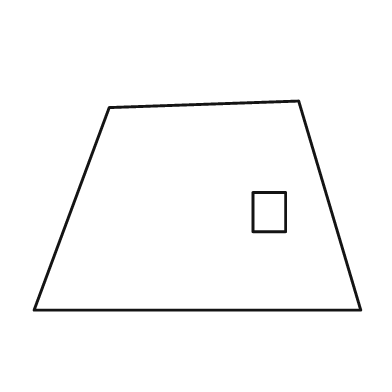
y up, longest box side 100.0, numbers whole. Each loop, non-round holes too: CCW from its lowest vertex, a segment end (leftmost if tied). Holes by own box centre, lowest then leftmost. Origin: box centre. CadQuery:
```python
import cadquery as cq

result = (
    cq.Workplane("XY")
    .moveTo(-50.0, -32.0)
    .lineTo(50.0, -32.0)
    .lineTo(31.0, 32.0)
    .lineTo(-27.0, 30.0)
    .close()
    .moveTo(17.0, -8.0)
    .lineTo(27.0, -8.0)
    .lineTo(27.0, 4.0)
    .lineTo(17.0, 4.0)
    .close()
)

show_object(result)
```